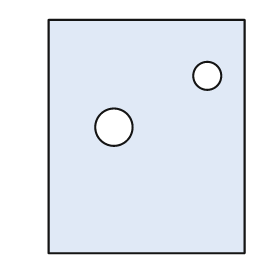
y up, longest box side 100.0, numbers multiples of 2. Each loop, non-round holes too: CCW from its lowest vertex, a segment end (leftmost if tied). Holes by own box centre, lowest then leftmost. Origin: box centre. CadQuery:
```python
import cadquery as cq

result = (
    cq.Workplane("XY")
    .moveTo(-42.0, -50.0)
    .lineTo(42.0, -50.0)
    .lineTo(42.0, 50.0)
    .lineTo(-42.0, 50.0)
    .close()
    .moveTo(-14.0, 4.0)
    .circle(8.0)
    .moveTo(26.0, 26.0)
    .circle(6.0)
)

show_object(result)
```